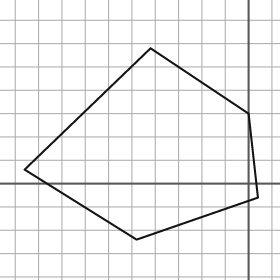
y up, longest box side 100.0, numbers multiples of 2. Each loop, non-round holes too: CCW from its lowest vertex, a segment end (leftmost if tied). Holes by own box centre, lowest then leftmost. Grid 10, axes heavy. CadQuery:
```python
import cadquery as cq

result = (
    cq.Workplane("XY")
    .moveTo(-48.0, -24.0)
    .lineTo(4.0, -6.0)
    .lineTo(0.0, 30.0)
    .lineTo(-42.0, 58.0)
    .lineTo(-96.0, 6.0)
    .close()
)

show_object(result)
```